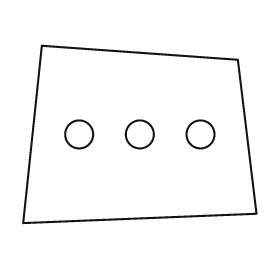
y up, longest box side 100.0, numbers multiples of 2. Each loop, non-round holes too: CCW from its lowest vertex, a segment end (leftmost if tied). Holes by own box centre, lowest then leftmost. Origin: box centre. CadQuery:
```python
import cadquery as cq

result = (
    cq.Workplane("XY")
    .moveTo(-50.0, -38.0)
    .lineTo(50.0, -34.0)
    .lineTo(42.0, 32.0)
    .lineTo(-42.0, 38.0)
    .close()
    .moveTo(-26.0, 0.0)
    .circle(6.0)
    .moveTo(0.0, 0.0)
    .circle(6.0)
    .moveTo(26.0, 0.0)
    .circle(6.0)
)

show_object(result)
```